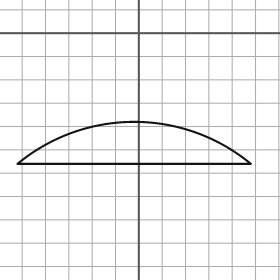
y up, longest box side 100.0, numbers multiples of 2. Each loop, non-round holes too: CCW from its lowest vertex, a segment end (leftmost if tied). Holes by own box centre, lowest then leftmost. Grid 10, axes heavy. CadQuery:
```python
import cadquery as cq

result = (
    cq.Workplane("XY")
    .moveTo(-52.0, -56.0)
    .lineTo(48.0, -56.0)
    .threePointArc((-2.0, -38.0), (-52.0, -56.0))
    .close()
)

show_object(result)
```